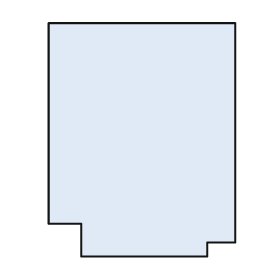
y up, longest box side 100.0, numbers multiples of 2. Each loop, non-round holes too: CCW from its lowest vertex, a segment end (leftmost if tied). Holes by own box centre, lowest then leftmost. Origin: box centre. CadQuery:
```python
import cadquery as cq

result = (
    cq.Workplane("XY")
    .moveTo(-26.0, -50.0)
    .lineTo(28.0, -50.0)
    .lineTo(28.0, -44.0)
    .lineTo(40.0, -44.0)
    .lineTo(40.0, 50.0)
    .lineTo(-40.0, 50.0)
    .lineTo(-40.0, -36.0)
    .lineTo(-26.0, -36.0)
    .close()
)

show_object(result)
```